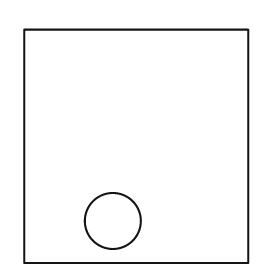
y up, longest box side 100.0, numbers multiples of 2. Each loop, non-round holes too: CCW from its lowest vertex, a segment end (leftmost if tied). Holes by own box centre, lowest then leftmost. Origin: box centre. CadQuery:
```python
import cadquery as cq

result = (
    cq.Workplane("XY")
    .moveTo(-48.0, -50.0)
    .lineTo(48.0, -50.0)
    .lineTo(48.0, 50.0)
    .lineTo(-48.0, 50.0)
    .close()
    .moveTo(-10.0, -32.0)
    .circle(12.0)
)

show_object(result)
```